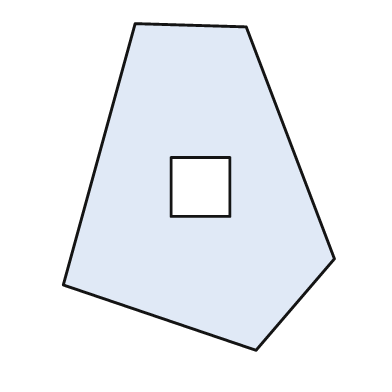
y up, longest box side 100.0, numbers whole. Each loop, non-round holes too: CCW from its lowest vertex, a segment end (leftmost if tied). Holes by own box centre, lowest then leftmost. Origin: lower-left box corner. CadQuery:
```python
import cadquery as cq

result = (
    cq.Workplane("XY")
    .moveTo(59.0, 0.0)
    .lineTo(83.0, 28.0)
    .lineTo(56.0, 99.0)
    .lineTo(22.0, 100.0)
    .lineTo(0.0, 20.0)
    .close()
    .moveTo(33.0, 41.0)
    .lineTo(51.0, 41.0)
    .lineTo(51.0, 59.0)
    .lineTo(33.0, 59.0)
    .close()
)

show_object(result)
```